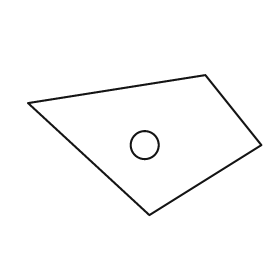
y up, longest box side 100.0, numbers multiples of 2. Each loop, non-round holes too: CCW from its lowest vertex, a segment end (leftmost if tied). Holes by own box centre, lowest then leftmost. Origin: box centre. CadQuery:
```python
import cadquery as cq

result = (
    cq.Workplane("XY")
    .moveTo(2.0, -30.0)
    .lineTo(50.0, 0.0)
    .lineTo(26.0, 30.0)
    .lineTo(-50.0, 18.0)
    .close()
    .moveTo(0.0, 0.0)
    .circle(6.0)
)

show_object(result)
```